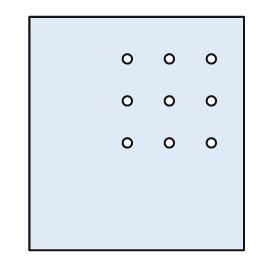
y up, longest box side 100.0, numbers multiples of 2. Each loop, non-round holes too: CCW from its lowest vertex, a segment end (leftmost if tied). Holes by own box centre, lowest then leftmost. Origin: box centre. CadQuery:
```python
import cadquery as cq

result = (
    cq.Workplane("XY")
    .moveTo(-46.0, -50.0)
    .lineTo(46.0, -50.0)
    .lineTo(46.0, 50.0)
    .lineTo(-46.0, 50.0)
    .close()
    .moveTo(-4.0, -4.0)
    .circle(2.0)
    .moveTo(14.0, -4.0)
    .circle(2.0)
    .moveTo(32.0, -4.0)
    .circle(2.0)
    .moveTo(-4.0, 14.0)
    .circle(2.0)
    .moveTo(14.0, 14.0)
    .circle(2.0)
    .moveTo(32.0, 14.0)
    .circle(2.0)
    .moveTo(-4.0, 32.0)
    .circle(2.0)
    .moveTo(14.0, 32.0)
    .circle(2.0)
    .moveTo(32.0, 32.0)
    .circle(2.0)
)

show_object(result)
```